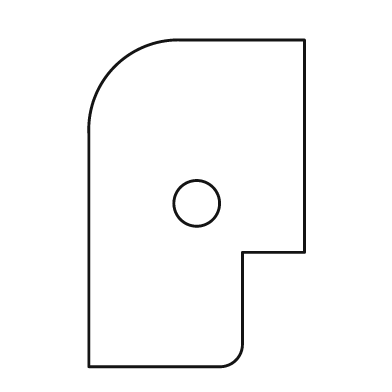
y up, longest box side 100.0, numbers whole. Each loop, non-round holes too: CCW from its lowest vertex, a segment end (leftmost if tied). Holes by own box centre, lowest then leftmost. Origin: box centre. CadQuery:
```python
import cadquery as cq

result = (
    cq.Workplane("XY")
    .moveTo(-33.0, -50.0)
    .lineTo(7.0, -50.0)
    .threePointArc((12.0, -48.0), (14.0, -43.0))
    .lineTo(14.0, -15.0)
    .lineTo(33.0, -15.0)
    .lineTo(33.0, 50.0)
    .lineTo(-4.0, 50.0)
    .threePointArc((-25.0, 42.0), (-33.0, 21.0))
    .close()
    .moveTo(0.0, 0.0)
    .circle(7.0)
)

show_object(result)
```